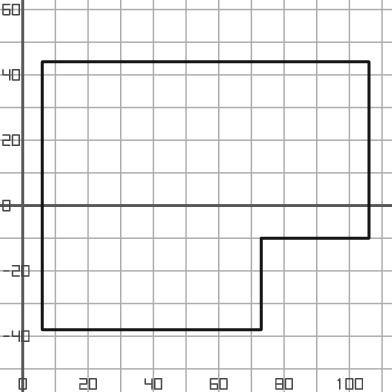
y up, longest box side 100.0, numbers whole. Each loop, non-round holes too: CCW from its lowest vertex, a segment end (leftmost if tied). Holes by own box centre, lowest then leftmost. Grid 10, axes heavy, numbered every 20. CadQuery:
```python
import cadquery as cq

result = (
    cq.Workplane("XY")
    .moveTo(6.0, -38.0)
    .lineTo(73.0, -38.0)
    .lineTo(73.0, -10.0)
    .lineTo(106.0, -10.0)
    .lineTo(106.0, 44.0)
    .lineTo(6.0, 44.0)
    .close()
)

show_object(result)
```